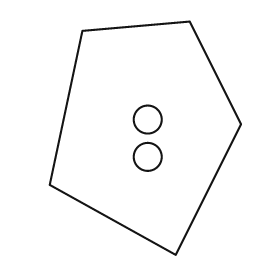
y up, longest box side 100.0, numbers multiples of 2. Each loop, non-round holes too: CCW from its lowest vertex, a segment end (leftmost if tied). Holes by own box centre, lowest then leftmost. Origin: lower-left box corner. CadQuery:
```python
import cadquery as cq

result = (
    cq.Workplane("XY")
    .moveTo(54.0, 0.0)
    .lineTo(82.0, 56.0)
    .lineTo(60.0, 100.0)
    .lineTo(14.0, 96.0)
    .lineTo(0.0, 30.0)
    .close()
    .moveTo(42.0, 42.0)
    .circle(6.0)
    .moveTo(42.0, 58.0)
    .circle(6.0)
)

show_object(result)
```